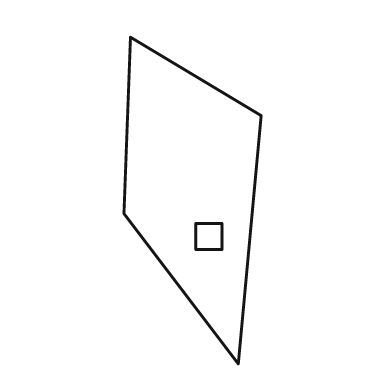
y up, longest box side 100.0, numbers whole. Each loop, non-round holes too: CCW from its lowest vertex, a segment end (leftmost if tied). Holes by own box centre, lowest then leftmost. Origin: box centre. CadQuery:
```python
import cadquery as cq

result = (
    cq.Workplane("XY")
    .moveTo(14.0, -50.0)
    .lineTo(21.0, 26.0)
    .lineTo(-19.0, 50.0)
    .lineTo(-21.0, -4.0)
    .close()
    .moveTo(1.0, -15.0)
    .lineTo(9.0, -15.0)
    .lineTo(9.0, -7.0)
    .lineTo(1.0, -7.0)
    .close()
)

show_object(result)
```